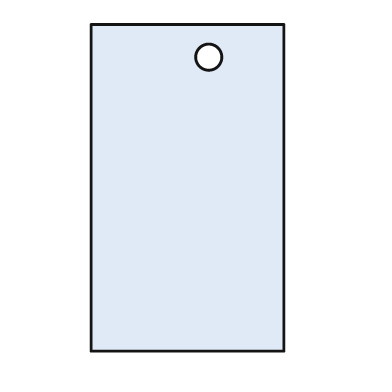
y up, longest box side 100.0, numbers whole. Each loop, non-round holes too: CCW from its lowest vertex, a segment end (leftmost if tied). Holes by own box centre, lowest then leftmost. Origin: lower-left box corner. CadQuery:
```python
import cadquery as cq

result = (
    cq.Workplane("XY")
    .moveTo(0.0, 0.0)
    .lineTo(59.0, 0.0)
    .lineTo(59.0, 100.0)
    .lineTo(0.0, 100.0)
    .close()
    .moveTo(36.0, 90.0)
    .circle(4.0)
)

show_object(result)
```